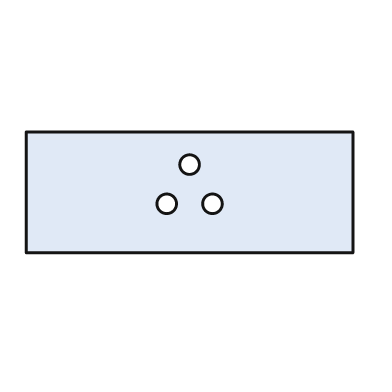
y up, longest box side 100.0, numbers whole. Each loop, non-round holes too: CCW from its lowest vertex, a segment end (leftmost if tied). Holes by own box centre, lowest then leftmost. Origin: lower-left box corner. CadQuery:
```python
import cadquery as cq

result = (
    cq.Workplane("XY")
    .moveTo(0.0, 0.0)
    .lineTo(100.0, 0.0)
    .lineTo(100.0, 37.0)
    .lineTo(0.0, 37.0)
    .close()
    .moveTo(43.0, 15.0)
    .circle(3.0)
    .moveTo(57.0, 15.0)
    .circle(3.0)
    .moveTo(50.0, 27.0)
    .circle(3.0)
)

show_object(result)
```